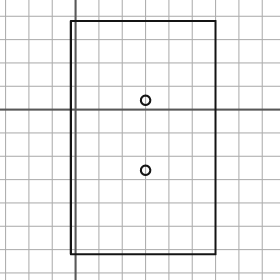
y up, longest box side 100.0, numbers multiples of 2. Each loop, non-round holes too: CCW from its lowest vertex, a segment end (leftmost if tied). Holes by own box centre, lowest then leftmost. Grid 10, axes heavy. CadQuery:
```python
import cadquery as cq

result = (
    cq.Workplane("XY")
    .moveTo(-2.0, -62.0)
    .lineTo(60.0, -62.0)
    .lineTo(60.0, 38.0)
    .lineTo(-2.0, 38.0)
    .close()
    .moveTo(30.0, -26.0)
    .circle(2.0)
    .moveTo(30.0, 4.0)
    .circle(2.0)
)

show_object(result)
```